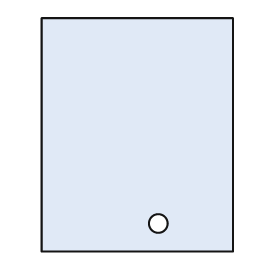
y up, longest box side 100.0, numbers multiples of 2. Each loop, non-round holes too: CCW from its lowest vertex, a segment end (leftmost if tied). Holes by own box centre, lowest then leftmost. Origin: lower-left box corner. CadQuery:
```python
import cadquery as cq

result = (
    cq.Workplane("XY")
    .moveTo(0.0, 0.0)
    .lineTo(82.0, 0.0)
    .lineTo(82.0, 100.0)
    .lineTo(0.0, 100.0)
    .close()
    .moveTo(50.0, 12.0)
    .circle(4.0)
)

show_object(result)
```